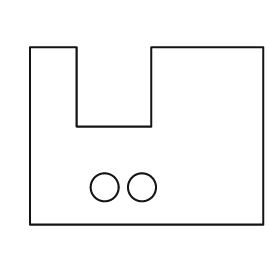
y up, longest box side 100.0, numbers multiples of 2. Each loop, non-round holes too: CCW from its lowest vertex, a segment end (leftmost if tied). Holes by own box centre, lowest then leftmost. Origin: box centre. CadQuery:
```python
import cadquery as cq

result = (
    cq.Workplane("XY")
    .moveTo(-50.0, -38.0)
    .lineTo(50.0, -38.0)
    .lineTo(50.0, 38.0)
    .lineTo(2.0, 38.0)
    .lineTo(2.0, 4.0)
    .lineTo(-30.0, 4.0)
    .lineTo(-30.0, 38.0)
    .lineTo(-50.0, 38.0)
    .close()
    .moveTo(-18.0, -22.0)
    .circle(6.0)
    .moveTo(-2.0, -22.0)
    .circle(6.0)
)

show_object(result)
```